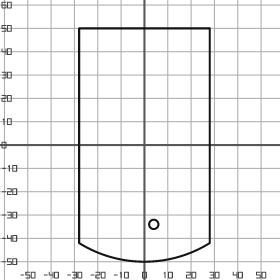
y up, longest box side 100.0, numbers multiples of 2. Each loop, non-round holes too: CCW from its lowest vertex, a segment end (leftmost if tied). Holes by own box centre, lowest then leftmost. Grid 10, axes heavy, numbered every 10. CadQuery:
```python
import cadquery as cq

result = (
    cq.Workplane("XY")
    .moveTo(-28.0, -42.0)
    .threePointArc((0.0, -50.0), (28.0, -42.0))
    .lineTo(28.0, 50.0)
    .lineTo(-28.0, 50.0)
    .close()
    .moveTo(4.0, -34.0)
    .circle(2.0)
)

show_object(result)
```